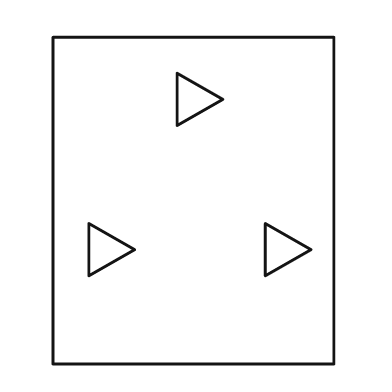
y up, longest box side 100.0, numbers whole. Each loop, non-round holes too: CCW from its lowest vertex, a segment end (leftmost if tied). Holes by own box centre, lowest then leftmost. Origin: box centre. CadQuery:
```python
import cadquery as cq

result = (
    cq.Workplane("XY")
    .moveTo(-43.0, -50.0)
    .lineTo(43.0, -50.0)
    .lineTo(43.0, 50.0)
    .lineTo(-43.0, 50.0)
    .close()
    .moveTo(-32.0, -23.0)
    .lineTo(-18.0, -15.0)
    .lineTo(-32.0, -7.0)
    .close()
    .moveTo(22.0, -23.0)
    .lineTo(36.0, -15.0)
    .lineTo(22.0, -7.0)
    .close()
    .moveTo(-5.0, 23.0)
    .lineTo(9.0, 31.0)
    .lineTo(-5.0, 39.0)
    .close()
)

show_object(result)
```